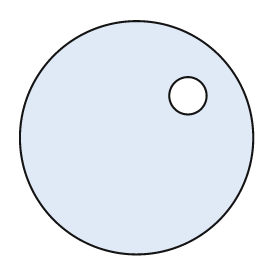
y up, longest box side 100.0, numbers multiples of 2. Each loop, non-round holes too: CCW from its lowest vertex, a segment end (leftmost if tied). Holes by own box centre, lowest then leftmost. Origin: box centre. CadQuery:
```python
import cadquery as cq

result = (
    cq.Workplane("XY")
    .moveTo(0.0, 0.0)
    .circle(50.0)
    .moveTo(22.0, 18.0)
    .circle(8.0)
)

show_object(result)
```